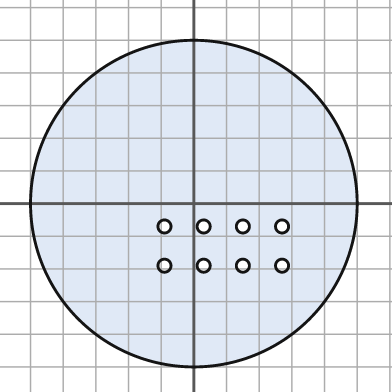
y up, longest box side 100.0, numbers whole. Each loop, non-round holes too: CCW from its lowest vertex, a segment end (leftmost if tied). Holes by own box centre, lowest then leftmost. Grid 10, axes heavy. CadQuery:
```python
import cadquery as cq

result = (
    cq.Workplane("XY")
    .moveTo(0.0, 0.0)
    .circle(50.0)
    .moveTo(-9.0, -19.0)
    .circle(2.0)
    .moveTo(3.0, -19.0)
    .circle(2.0)
    .moveTo(15.0, -19.0)
    .circle(2.0)
    .moveTo(27.0, -19.0)
    .circle(2.0)
    .moveTo(-9.0, -7.0)
    .circle(2.0)
    .moveTo(3.0, -7.0)
    .circle(2.0)
    .moveTo(15.0, -7.0)
    .circle(2.0)
    .moveTo(27.0, -7.0)
    .circle(2.0)
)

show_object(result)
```